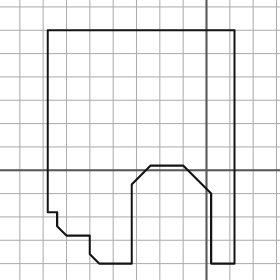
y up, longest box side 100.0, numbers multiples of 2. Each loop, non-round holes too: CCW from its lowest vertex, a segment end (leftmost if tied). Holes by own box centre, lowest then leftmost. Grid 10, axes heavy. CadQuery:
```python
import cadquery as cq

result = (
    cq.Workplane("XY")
    .moveTo(-46.0, -40.0)
    .lineTo(-32.0, -40.0)
    .lineTo(-32.0, -6.0)
    .lineTo(-24.0, 2.0)
    .lineTo(-10.0, 2.0)
    .lineTo(2.0, -10.0)
    .lineTo(2.0, -40.0)
    .lineTo(12.0, -40.0)
    .lineTo(12.0, 60.0)
    .lineTo(-68.0, 60.0)
    .lineTo(-68.0, -18.0)
    .lineTo(-64.0, -18.0)
    .lineTo(-64.0, -24.0)
    .lineTo(-60.0, -28.0)
    .lineTo(-50.0, -28.0)
    .lineTo(-50.0, -36.0)
    .close()
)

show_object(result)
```